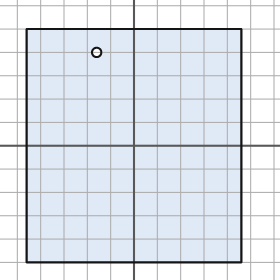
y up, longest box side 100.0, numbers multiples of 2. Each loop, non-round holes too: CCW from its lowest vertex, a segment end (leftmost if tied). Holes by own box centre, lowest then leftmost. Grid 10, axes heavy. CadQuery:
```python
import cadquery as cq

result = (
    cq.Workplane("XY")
    .moveTo(-46.0, -50.0)
    .lineTo(46.0, -50.0)
    .lineTo(46.0, 50.0)
    .lineTo(-46.0, 50.0)
    .close()
    .moveTo(-16.0, 40.0)
    .circle(2.0)
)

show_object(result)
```